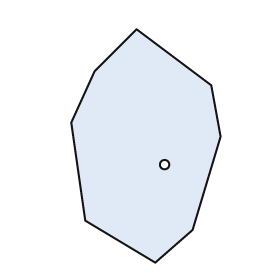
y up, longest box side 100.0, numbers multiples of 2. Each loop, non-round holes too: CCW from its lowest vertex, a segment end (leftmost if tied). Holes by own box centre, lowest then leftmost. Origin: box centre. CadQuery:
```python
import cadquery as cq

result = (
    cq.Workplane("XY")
    .moveTo(4.0, -50.0)
    .lineTo(20.0, -36.0)
    .lineTo(32.0, 4.0)
    .lineTo(28.0, 26.0)
    .lineTo(-4.0, 50.0)
    .lineTo(-22.0, 32.0)
    .lineTo(-32.0, 10.0)
    .lineTo(-26.0, -32.0)
    .close()
    .moveTo(8.0, -8.0)
    .circle(2.0)
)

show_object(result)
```